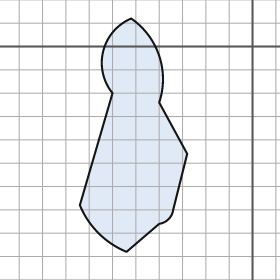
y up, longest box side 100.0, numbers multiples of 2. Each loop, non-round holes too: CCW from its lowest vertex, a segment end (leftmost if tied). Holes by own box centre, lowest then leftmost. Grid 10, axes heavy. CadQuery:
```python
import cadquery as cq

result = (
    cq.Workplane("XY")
    .moveTo(-54.0, -88.0)
    .lineTo(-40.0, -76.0)
    .threePointArc((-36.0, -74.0), (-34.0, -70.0))
    .lineTo(-28.0, -46.0)
    .lineTo(-40.0, -24.0)
    .threePointArc((-40.0, -4.0), (-52.0, 12.0))
    .threePointArc((-64.0, -2.0), (-60.0, -20.0))
    .lineTo(-74.0, -68.0)
    .threePointArc((-66.0, -80.0), (-54.0, -88.0))
    .close()
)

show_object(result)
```